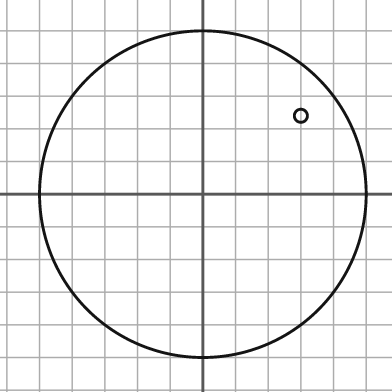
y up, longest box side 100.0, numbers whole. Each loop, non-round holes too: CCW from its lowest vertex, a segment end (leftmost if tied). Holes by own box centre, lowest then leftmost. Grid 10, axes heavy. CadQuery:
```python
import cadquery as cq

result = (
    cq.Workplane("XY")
    .moveTo(0.0, 0.0)
    .circle(50.0)
    .moveTo(30.0, 24.0)
    .circle(2.0)
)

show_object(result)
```